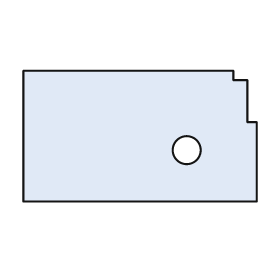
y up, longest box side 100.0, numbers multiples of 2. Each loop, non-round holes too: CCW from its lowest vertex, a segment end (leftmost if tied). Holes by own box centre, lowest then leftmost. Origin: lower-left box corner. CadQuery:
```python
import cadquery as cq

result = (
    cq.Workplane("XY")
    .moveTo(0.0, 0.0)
    .lineTo(100.0, 0.0)
    .lineTo(100.0, 34.0)
    .lineTo(96.0, 34.0)
    .lineTo(96.0, 52.0)
    .lineTo(90.0, 52.0)
    .lineTo(90.0, 56.0)
    .lineTo(0.0, 56.0)
    .close()
    .moveTo(70.0, 22.0)
    .circle(6.0)
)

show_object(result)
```